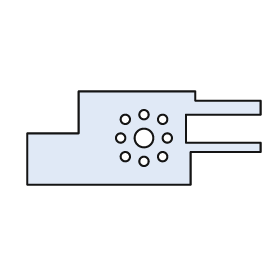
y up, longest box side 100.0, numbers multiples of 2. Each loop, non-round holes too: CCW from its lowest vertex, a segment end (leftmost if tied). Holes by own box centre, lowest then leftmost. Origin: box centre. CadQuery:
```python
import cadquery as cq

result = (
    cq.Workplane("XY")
    .moveTo(-50.0, -20.0)
    .lineTo(20.0, -20.0)
    .lineTo(20.0, -6.0)
    .lineTo(50.0, -6.0)
    .lineTo(50.0, -2.0)
    .lineTo(18.0, -2.0)
    .lineTo(18.0, 10.0)
    .lineTo(50.0, 10.0)
    .lineTo(50.0, 16.0)
    .lineTo(22.0, 16.0)
    .lineTo(22.0, 20.0)
    .lineTo(-28.0, 20.0)
    .lineTo(-28.0, 2.0)
    .lineTo(-50.0, 2.0)
    .close()
    .moveTo(0.0, -10.0)
    .circle(2.0)
    .moveTo(-8.0, -8.0)
    .circle(2.0)
    .moveTo(8.0, -8.0)
    .circle(2.0)
    .moveTo(-10.0, 0.0)
    .circle(2.0)
    .moveTo(0.0, 0.0)
    .circle(4.0)
    .moveTo(10.0, 0.0)
    .circle(2.0)
    .moveTo(-8.0, 8.0)
    .circle(2.0)
    .moveTo(8.0, 8.0)
    .circle(2.0)
    .moveTo(0.0, 10.0)
    .circle(2.0)
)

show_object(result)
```